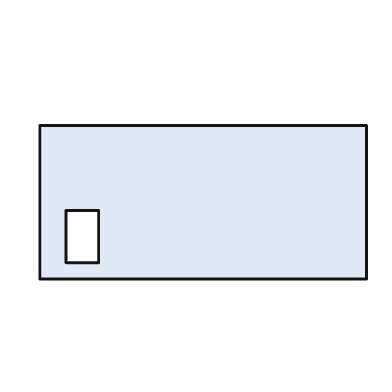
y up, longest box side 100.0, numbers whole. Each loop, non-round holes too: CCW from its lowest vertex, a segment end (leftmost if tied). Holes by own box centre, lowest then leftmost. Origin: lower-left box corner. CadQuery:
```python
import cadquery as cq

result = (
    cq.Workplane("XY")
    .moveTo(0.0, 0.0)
    .lineTo(100.0, 0.0)
    .lineTo(100.0, 47.0)
    .lineTo(0.0, 47.0)
    .close()
    .moveTo(8.0, 5.0)
    .lineTo(18.0, 5.0)
    .lineTo(18.0, 21.0)
    .lineTo(8.0, 21.0)
    .close()
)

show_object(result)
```